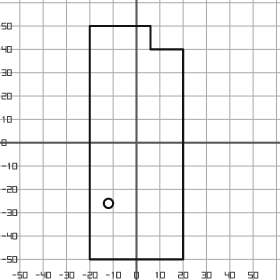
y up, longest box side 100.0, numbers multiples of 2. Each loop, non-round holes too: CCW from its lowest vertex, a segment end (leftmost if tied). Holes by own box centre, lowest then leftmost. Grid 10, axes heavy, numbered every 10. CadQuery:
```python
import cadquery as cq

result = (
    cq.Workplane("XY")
    .moveTo(-20.0, -50.0)
    .lineTo(20.0, -50.0)
    .lineTo(20.0, 40.0)
    .lineTo(6.0, 40.0)
    .lineTo(6.0, 50.0)
    .lineTo(-20.0, 50.0)
    .close()
    .moveTo(-12.0, -26.0)
    .circle(2.0)
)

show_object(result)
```